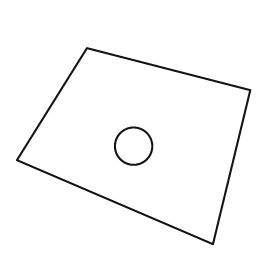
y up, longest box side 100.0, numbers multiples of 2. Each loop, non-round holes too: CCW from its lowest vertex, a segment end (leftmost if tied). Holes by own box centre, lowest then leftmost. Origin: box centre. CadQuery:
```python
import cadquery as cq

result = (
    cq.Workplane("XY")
    .moveTo(34.0, -42.0)
    .lineTo(50.0, 24.0)
    .lineTo(-20.0, 42.0)
    .lineTo(-50.0, -6.0)
    .close()
    .moveTo(0.0, 0.0)
    .circle(8.0)
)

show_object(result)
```